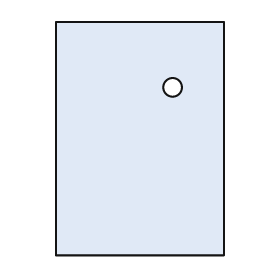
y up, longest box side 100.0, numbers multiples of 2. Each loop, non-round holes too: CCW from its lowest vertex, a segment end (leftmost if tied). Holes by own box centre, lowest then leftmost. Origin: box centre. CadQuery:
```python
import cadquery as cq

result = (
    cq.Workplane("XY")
    .moveTo(-36.0, -50.0)
    .lineTo(36.0, -50.0)
    .lineTo(36.0, 50.0)
    .lineTo(-36.0, 50.0)
    .close()
    .moveTo(14.0, 22.0)
    .circle(4.0)
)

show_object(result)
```